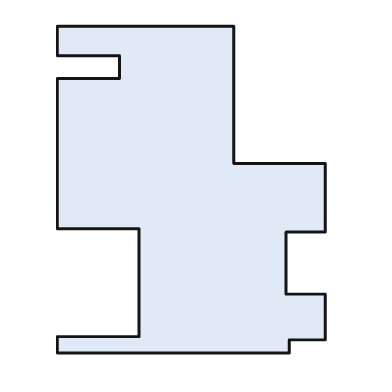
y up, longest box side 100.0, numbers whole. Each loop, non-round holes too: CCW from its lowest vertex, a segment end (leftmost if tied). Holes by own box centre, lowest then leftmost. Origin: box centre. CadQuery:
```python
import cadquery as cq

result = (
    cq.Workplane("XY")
    .moveTo(-41.0, -50.0)
    .lineTo(30.0, -50.0)
    .lineTo(30.0, -46.0)
    .lineTo(41.0, -46.0)
    .lineTo(41.0, -32.0)
    .lineTo(29.0, -32.0)
    .lineTo(29.0, -13.0)
    .lineTo(41.0, -13.0)
    .lineTo(41.0, 8.0)
    .lineTo(13.0, 8.0)
    .lineTo(13.0, 50.0)
    .lineTo(-41.0, 50.0)
    .lineTo(-41.0, 41.0)
    .lineTo(-22.0, 41.0)
    .lineTo(-22.0, 34.0)
    .lineTo(-41.0, 34.0)
    .lineTo(-41.0, -12.0)
    .lineTo(-16.0, -12.0)
    .lineTo(-16.0, -45.0)
    .lineTo(-41.0, -45.0)
    .close()
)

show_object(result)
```